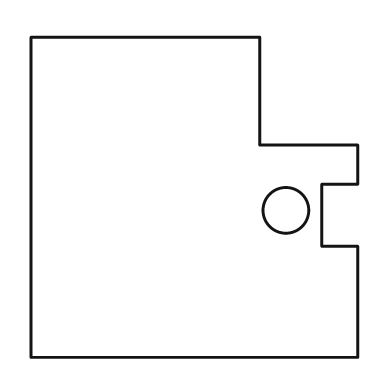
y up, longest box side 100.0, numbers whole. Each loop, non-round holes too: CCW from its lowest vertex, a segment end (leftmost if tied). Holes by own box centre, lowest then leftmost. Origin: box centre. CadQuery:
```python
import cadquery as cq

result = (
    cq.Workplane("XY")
    .moveTo(-50.0, -49.0)
    .lineTo(50.0, -49.0)
    .lineTo(50.0, -15.0)
    .lineTo(39.0, -15.0)
    .lineTo(39.0, 4.0)
    .lineTo(50.0, 4.0)
    .lineTo(50.0, 16.0)
    .lineTo(20.0, 16.0)
    .lineTo(20.0, 49.0)
    .lineTo(-50.0, 49.0)
    .close()
    .moveTo(28.0, -4.0)
    .circle(7.0)
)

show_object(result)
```